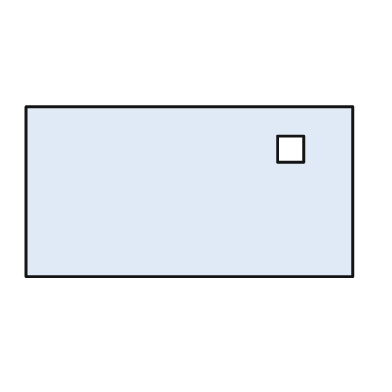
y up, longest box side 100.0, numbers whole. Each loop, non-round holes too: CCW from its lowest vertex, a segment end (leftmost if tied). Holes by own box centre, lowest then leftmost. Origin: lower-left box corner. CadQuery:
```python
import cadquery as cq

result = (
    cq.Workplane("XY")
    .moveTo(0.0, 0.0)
    .lineTo(100.0, 0.0)
    .lineTo(100.0, 52.0)
    .lineTo(0.0, 52.0)
    .close()
    .moveTo(77.0, 35.0)
    .lineTo(85.0, 35.0)
    .lineTo(85.0, 43.0)
    .lineTo(77.0, 43.0)
    .close()
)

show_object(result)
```